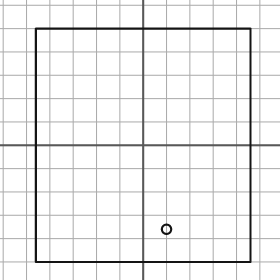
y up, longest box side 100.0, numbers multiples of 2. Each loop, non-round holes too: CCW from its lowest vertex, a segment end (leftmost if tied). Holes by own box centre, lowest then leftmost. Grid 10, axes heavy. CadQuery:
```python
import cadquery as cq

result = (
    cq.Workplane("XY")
    .moveTo(-46.0, -50.0)
    .lineTo(46.0, -50.0)
    .lineTo(46.0, 50.0)
    .lineTo(-46.0, 50.0)
    .close()
    .moveTo(10.0, -36.0)
    .circle(2.0)
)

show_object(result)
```